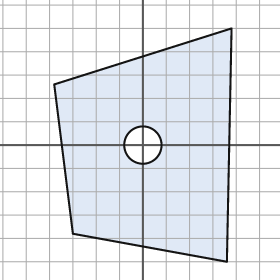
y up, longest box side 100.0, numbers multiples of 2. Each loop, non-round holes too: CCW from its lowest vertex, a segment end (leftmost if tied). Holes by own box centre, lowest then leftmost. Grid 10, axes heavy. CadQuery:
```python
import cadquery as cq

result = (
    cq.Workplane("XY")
    .moveTo(36.0, -50.0)
    .lineTo(38.0, 50.0)
    .lineTo(-38.0, 26.0)
    .lineTo(-30.0, -38.0)
    .close()
    .moveTo(0.0, 0.0)
    .circle(8.0)
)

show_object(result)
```